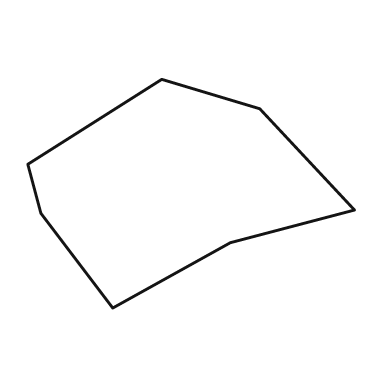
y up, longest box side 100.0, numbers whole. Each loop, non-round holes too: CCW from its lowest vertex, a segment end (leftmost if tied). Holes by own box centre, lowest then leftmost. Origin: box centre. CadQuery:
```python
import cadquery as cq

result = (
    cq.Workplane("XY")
    .moveTo(-24.0, -35.0)
    .lineTo(12.0, -15.0)
    .lineTo(50.0, -5.0)
    .lineTo(21.0, 26.0)
    .lineTo(-9.0, 35.0)
    .lineTo(-50.0, 9.0)
    .lineTo(-46.0, -6.0)
    .close()
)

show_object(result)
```